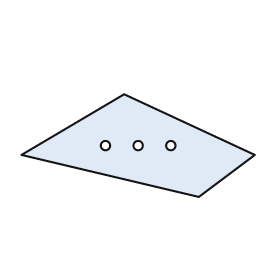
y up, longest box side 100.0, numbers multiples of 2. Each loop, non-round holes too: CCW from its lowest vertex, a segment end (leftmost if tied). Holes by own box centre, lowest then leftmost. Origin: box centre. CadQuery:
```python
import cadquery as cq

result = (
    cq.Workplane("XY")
    .moveTo(26.0, -22.0)
    .lineTo(50.0, -4.0)
    .lineTo(-6.0, 22.0)
    .lineTo(-50.0, -4.0)
    .close()
    .moveTo(-14.0, 0.0)
    .circle(2.0)
    .moveTo(0.0, 0.0)
    .circle(2.0)
    .moveTo(14.0, 0.0)
    .circle(2.0)
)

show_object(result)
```